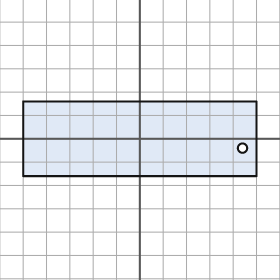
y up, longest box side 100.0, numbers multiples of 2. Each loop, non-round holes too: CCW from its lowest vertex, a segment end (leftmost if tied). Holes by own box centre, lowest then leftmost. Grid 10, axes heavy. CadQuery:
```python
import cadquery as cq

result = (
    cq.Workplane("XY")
    .moveTo(-50.0, -16.0)
    .lineTo(50.0, -16.0)
    .lineTo(50.0, 16.0)
    .lineTo(-50.0, 16.0)
    .close()
    .moveTo(44.0, -4.0)
    .circle(2.0)
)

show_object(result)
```